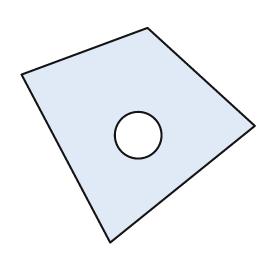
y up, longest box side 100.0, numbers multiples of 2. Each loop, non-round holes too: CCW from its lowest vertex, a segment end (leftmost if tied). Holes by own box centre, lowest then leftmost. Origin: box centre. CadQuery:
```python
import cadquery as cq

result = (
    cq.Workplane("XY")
    .moveTo(-12.0, -46.0)
    .lineTo(50.0, 4.0)
    .lineTo(4.0, 46.0)
    .lineTo(-50.0, 26.0)
    .close()
    .moveTo(0.0, 0.0)
    .circle(10.0)
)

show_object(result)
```